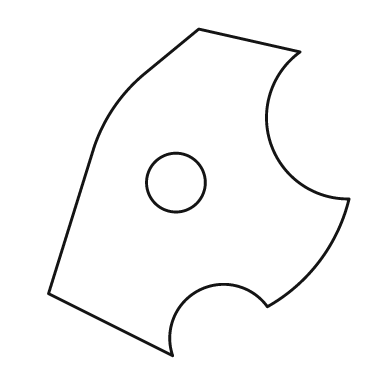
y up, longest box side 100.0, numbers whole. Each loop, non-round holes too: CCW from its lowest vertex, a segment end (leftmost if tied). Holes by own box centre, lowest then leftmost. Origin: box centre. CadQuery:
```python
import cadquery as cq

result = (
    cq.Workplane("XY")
    .moveTo(-8.0, -50.0)
    .threePointArc((0.0, -30.0), (21.0, -35.0))
    .threePointArc((37.0, -21.0), (46.0, -2.0))
    .threePointArc((22.0, 15.0), (31.0, 43.0))
    .lineTo(0.0, 50.0)
    .lineTo(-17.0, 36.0)
    .threePointArc((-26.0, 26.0), (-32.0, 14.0))
    .lineTo(-46.0, -31.0)
    .close()
    .moveTo(-7.0, 3.0)
    .circle(9.0)
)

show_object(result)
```